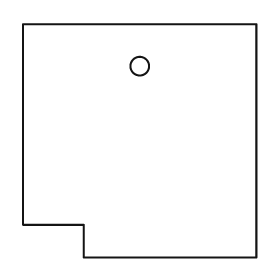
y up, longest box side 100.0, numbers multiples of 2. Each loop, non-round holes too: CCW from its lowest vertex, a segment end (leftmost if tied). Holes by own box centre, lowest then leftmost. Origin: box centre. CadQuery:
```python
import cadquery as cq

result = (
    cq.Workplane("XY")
    .moveTo(-24.0, -50.0)
    .lineTo(50.0, -50.0)
    .lineTo(50.0, 50.0)
    .lineTo(-50.0, 50.0)
    .lineTo(-50.0, -36.0)
    .lineTo(-24.0, -36.0)
    .close()
    .moveTo(0.0, 32.0)
    .circle(4.0)
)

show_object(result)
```